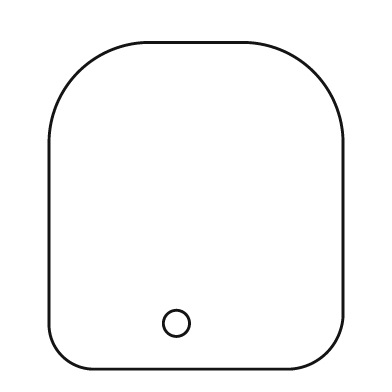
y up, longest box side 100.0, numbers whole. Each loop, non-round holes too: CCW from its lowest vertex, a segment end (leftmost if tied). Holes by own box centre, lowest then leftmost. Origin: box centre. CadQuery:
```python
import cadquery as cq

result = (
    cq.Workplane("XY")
    .moveTo(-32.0, -50.0)
    .lineTo(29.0, -50.0)
    .threePointArc((40.0, -45.0), (45.0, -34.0))
    .lineTo(45.0, 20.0)
    .threePointArc((36.0, 41.0), (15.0, 50.0))
    .lineTo(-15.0, 50.0)
    .threePointArc((-36.0, 41.0), (-45.0, 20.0))
    .lineTo(-45.0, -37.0)
    .threePointArc((-41.0, -46.0), (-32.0, -50.0))
    .close()
    .moveTo(-6.0, -36.0)
    .circle(4.0)
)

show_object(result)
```